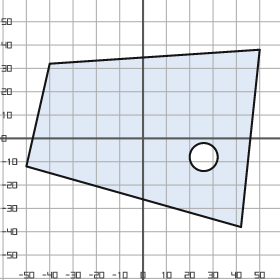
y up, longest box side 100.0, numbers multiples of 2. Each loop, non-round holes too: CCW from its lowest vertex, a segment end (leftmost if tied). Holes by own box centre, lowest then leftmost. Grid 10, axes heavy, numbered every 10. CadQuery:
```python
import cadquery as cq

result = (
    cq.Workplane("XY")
    .moveTo(42.0, -38.0)
    .lineTo(50.0, 38.0)
    .lineTo(-40.0, 32.0)
    .lineTo(-50.0, -12.0)
    .close()
    .moveTo(26.0, -8.0)
    .circle(6.0)
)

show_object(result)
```